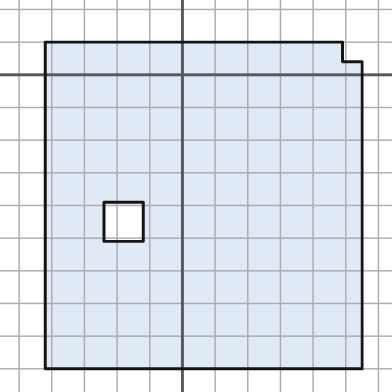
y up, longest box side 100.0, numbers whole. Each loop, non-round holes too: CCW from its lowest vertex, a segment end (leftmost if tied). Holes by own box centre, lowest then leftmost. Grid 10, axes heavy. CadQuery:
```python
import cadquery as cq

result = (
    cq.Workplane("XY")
    .moveTo(-42.0, -90.0)
    .lineTo(55.0, -90.0)
    .lineTo(55.0, 4.0)
    .lineTo(49.0, 4.0)
    .lineTo(49.0, 10.0)
    .lineTo(-42.0, 10.0)
    .close()
    .moveTo(-24.0, -51.0)
    .lineTo(-12.0, -51.0)
    .lineTo(-12.0, -39.0)
    .lineTo(-24.0, -39.0)
    .close()
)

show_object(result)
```